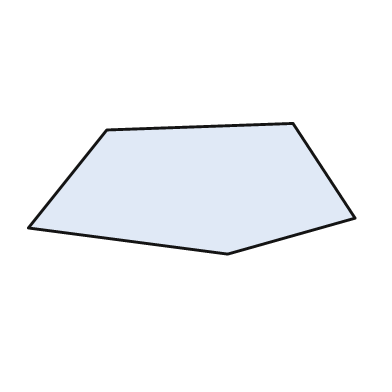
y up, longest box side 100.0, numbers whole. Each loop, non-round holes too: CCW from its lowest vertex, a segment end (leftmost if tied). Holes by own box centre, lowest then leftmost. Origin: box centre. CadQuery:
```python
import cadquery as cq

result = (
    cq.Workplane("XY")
    .moveTo(11.0, -20.0)
    .lineTo(50.0, -9.0)
    .lineTo(31.0, 20.0)
    .lineTo(-26.0, 18.0)
    .lineTo(-50.0, -12.0)
    .close()
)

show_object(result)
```